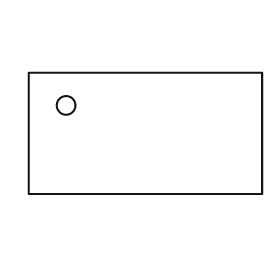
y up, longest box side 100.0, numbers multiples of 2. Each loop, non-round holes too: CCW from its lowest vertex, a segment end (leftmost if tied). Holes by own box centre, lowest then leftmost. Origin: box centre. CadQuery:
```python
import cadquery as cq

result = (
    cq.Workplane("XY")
    .moveTo(-50.0, -26.0)
    .lineTo(50.0, -26.0)
    .lineTo(50.0, 26.0)
    .lineTo(-50.0, 26.0)
    .close()
    .moveTo(-34.0, 12.0)
    .circle(4.0)
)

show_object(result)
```